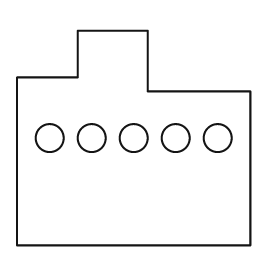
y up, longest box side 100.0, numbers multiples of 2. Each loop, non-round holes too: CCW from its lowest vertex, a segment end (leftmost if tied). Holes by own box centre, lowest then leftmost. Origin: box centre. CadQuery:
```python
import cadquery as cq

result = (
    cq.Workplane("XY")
    .moveTo(-50.0, -46.0)
    .lineTo(50.0, -46.0)
    .lineTo(50.0, 20.0)
    .lineTo(6.0, 20.0)
    .lineTo(6.0, 46.0)
    .lineTo(-24.0, 46.0)
    .lineTo(-24.0, 26.0)
    .lineTo(-50.0, 26.0)
    .close()
    .moveTo(-36.0, 0.0)
    .circle(6.0)
    .moveTo(-18.0, 0.0)
    .circle(6.0)
    .moveTo(0.0, 0.0)
    .circle(6.0)
    .moveTo(18.0, 0.0)
    .circle(6.0)
    .moveTo(36.0, 0.0)
    .circle(6.0)
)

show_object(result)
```